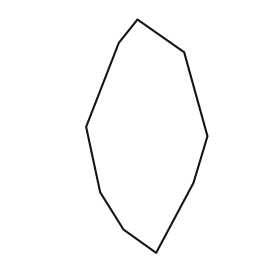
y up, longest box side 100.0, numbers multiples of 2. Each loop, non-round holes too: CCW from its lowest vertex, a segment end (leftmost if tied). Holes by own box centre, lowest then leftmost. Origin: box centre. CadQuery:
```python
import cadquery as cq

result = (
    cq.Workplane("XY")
    .moveTo(4.0, -50.0)
    .lineTo(20.0, -20.0)
    .lineTo(26.0, 0.0)
    .lineTo(16.0, 36.0)
    .lineTo(-4.0, 50.0)
    .lineTo(-12.0, 40.0)
    .lineTo(-26.0, 4.0)
    .lineTo(-20.0, -24.0)
    .lineTo(-10.0, -40.0)
    .close()
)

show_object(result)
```